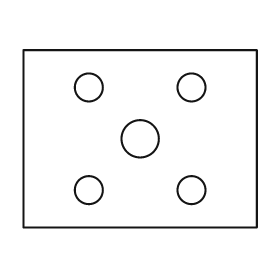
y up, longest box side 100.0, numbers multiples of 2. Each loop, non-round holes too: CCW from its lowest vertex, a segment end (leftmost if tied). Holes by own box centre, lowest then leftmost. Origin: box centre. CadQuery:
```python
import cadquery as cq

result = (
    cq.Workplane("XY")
    .moveTo(-50.0, -38.0)
    .lineTo(50.0, -38.0)
    .lineTo(50.0, 38.0)
    .lineTo(-50.0, 38.0)
    .close()
    .moveTo(-22.0, -22.0)
    .circle(6.0)
    .moveTo(22.0, -22.0)
    .circle(6.0)
    .moveTo(0.0, 0.0)
    .circle(8.0)
    .moveTo(-22.0, 22.0)
    .circle(6.0)
    .moveTo(22.0, 22.0)
    .circle(6.0)
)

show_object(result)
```